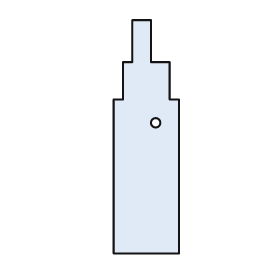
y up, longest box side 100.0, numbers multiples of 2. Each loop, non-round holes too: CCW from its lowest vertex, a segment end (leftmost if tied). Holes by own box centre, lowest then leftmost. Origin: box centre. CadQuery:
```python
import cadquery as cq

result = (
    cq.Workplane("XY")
    .moveTo(-14.0, -50.0)
    .lineTo(14.0, -50.0)
    .lineTo(14.0, 16.0)
    .lineTo(10.0, 16.0)
    .lineTo(10.0, 32.0)
    .lineTo(2.0, 32.0)
    .lineTo(2.0, 50.0)
    .lineTo(-6.0, 50.0)
    .lineTo(-6.0, 32.0)
    .lineTo(-10.0, 32.0)
    .lineTo(-10.0, 16.0)
    .lineTo(-14.0, 16.0)
    .close()
    .moveTo(4.0, 6.0)
    .circle(2.0)
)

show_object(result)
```